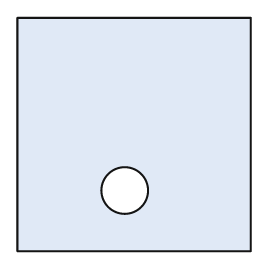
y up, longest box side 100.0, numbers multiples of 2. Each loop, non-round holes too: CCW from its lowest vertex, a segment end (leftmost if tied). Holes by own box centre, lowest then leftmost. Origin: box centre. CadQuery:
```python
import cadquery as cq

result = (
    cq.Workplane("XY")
    .moveTo(-50.0, -50.0)
    .lineTo(50.0, -50.0)
    .lineTo(50.0, 50.0)
    .lineTo(-50.0, 50.0)
    .close()
    .moveTo(-4.0, -24.0)
    .circle(10.0)
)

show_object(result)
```